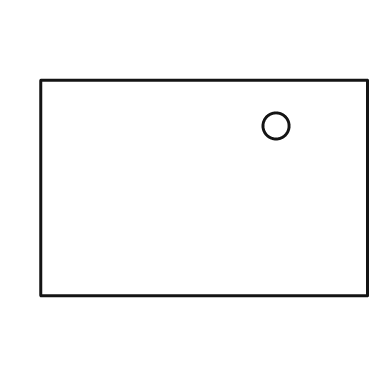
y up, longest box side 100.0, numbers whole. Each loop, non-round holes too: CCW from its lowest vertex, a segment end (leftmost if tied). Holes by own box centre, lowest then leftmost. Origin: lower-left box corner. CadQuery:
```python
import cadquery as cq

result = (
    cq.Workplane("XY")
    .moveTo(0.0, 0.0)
    .lineTo(100.0, 0.0)
    .lineTo(100.0, 66.0)
    .lineTo(0.0, 66.0)
    .close()
    .moveTo(72.0, 52.0)
    .circle(4.0)
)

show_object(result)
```